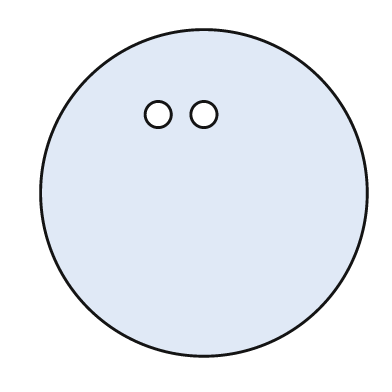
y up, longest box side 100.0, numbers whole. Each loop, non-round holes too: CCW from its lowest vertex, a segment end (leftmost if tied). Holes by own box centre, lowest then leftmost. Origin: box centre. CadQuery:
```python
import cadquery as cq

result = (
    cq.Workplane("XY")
    .moveTo(0.0, 0.0)
    .circle(50.0)
    .moveTo(-14.0, 24.0)
    .circle(4.0)
    .moveTo(0.0, 24.0)
    .circle(4.0)
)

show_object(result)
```